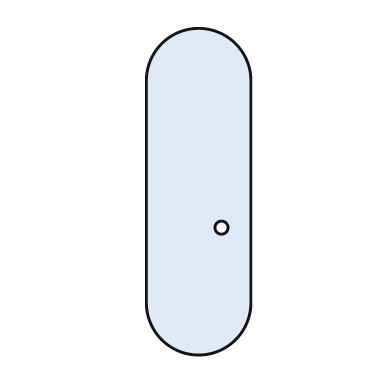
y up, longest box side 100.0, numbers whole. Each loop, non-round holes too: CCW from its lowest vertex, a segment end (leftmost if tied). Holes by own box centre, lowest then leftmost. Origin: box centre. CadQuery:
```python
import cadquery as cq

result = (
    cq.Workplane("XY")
    .moveTo(-16.0, -34.0)
    .threePointArc((0.0, -50.0), (16.0, -34.0))
    .lineTo(16.0, 34.0)
    .threePointArc((0.0, 50.0), (-16.0, 34.0))
    .close()
    .moveTo(7.0, -11.0)
    .circle(2.0)
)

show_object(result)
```